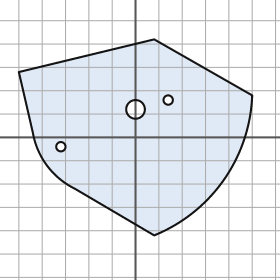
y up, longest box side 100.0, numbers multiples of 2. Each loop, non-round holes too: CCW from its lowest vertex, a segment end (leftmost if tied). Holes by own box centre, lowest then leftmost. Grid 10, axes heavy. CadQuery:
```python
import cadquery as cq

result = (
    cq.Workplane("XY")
    .moveTo(8.0, -42.0)
    .threePointArc((38.0, -18.0), (50.0, 18.0))
    .lineTo(8.0, 42.0)
    .lineTo(-50.0, 28.0)
    .lineTo(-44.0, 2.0)
    .threePointArc((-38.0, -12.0), (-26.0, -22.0))
    .close()
    .moveTo(-32.0, -4.0)
    .circle(2.0)
    .moveTo(0.0, 12.0)
    .circle(4.0)
    .moveTo(14.0, 16.0)
    .circle(2.0)
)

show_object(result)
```